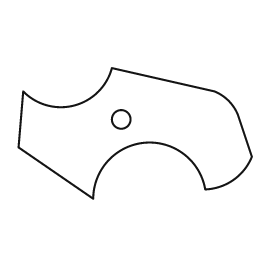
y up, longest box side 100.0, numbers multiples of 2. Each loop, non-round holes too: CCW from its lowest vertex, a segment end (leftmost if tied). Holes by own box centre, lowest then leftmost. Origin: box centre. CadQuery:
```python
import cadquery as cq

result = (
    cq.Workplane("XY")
    .moveTo(-18.0, -28.0)
    .threePointArc((4.0, -4.0), (30.0, -24.0))
    .threePointArc((42.0, -20.0), (50.0, -10.0))
    .lineTo(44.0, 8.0)
    .threePointArc((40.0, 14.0), (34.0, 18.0))
    .lineTo(-10.0, 28.0)
    .threePointArc((-26.0, 12.0), (-48.0, 18.0))
    .lineTo(-50.0, -6.0)
    .close()
    .moveTo(-6.0, 6.0)
    .circle(4.0)
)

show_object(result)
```